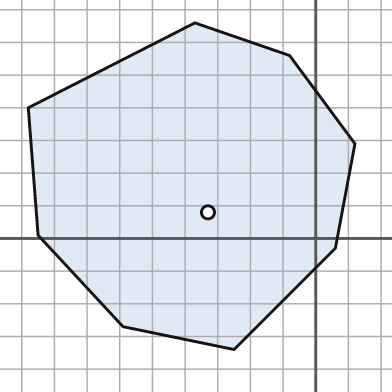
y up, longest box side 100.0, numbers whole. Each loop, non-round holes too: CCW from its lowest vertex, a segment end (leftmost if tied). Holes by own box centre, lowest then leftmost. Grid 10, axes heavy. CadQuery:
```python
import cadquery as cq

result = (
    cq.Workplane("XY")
    .moveTo(-25.0, -34.0)
    .lineTo(6.0, -3.0)
    .lineTo(12.0, 29.0)
    .lineTo(-8.0, 56.0)
    .lineTo(-37.0, 66.0)
    .lineTo(-88.0, 40.0)
    .lineTo(-85.0, 1.0)
    .lineTo(-59.0, -27.0)
    .close()
    .moveTo(-33.0, 8.0)
    .circle(2.0)
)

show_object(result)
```